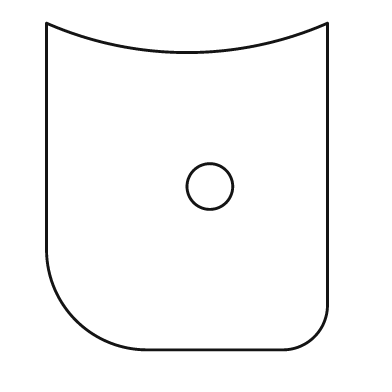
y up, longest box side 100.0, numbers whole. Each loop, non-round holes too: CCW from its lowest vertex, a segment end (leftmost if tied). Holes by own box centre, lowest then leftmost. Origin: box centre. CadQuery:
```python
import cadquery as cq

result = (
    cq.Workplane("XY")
    .moveTo(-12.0, -50.0)
    .lineTo(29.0, -50.0)
    .threePointArc((39.0, -46.0), (43.0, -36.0))
    .lineTo(43.0, 50.0)
    .threePointArc((0.0, 41.0), (-43.0, 50.0))
    .lineTo(-43.0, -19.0)
    .threePointArc((-34.0, -41.0), (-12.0, -50.0))
    .close()
    .moveTo(7.0, 0.0)
    .circle(7.0)
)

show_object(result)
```